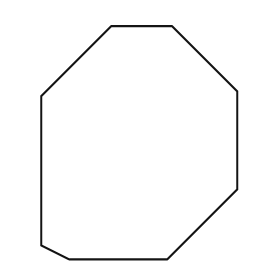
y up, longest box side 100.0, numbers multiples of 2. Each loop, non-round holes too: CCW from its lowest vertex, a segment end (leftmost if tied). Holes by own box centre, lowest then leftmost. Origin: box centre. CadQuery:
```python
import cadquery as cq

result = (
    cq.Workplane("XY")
    .moveTo(-30.0, -50.0)
    .lineTo(12.0, -50.0)
    .lineTo(42.0, -20.0)
    .lineTo(42.0, 22.0)
    .lineTo(14.0, 50.0)
    .lineTo(-12.0, 50.0)
    .lineTo(-42.0, 20.0)
    .lineTo(-42.0, -44.0)
    .close()
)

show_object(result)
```